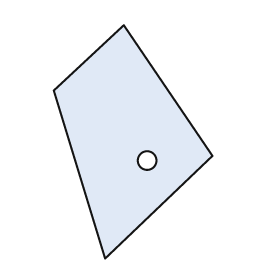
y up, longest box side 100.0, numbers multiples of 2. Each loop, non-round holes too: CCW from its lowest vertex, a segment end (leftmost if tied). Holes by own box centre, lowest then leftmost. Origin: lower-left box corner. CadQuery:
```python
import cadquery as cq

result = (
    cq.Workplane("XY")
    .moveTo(22.0, 0.0)
    .lineTo(68.0, 44.0)
    .lineTo(30.0, 100.0)
    .lineTo(0.0, 72.0)
    .close()
    .moveTo(40.0, 42.0)
    .circle(4.0)
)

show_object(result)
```